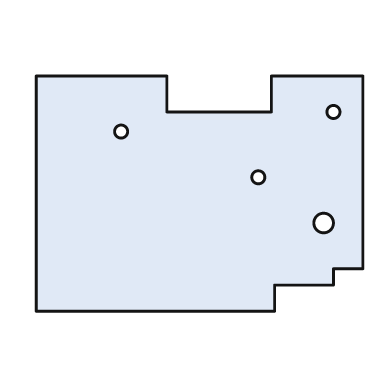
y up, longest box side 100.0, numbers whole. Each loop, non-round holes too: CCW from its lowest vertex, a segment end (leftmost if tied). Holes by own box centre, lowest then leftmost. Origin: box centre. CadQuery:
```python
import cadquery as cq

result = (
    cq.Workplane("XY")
    .moveTo(-50.0, -36.0)
    .lineTo(23.0, -36.0)
    .lineTo(23.0, -28.0)
    .lineTo(41.0, -28.0)
    .lineTo(41.0, -23.0)
    .lineTo(50.0, -23.0)
    .lineTo(50.0, 36.0)
    .lineTo(22.0, 36.0)
    .lineTo(22.0, 25.0)
    .lineTo(-10.0, 25.0)
    .lineTo(-10.0, 36.0)
    .lineTo(-50.0, 36.0)
    .close()
    .moveTo(38.0, -9.0)
    .circle(3.0)
    .moveTo(18.0, 5.0)
    .circle(2.0)
    .moveTo(-24.0, 19.0)
    .circle(2.0)
    .moveTo(41.0, 25.0)
    .circle(2.0)
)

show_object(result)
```